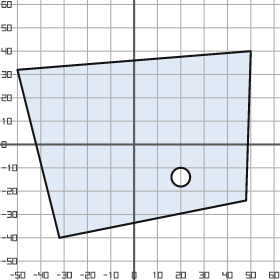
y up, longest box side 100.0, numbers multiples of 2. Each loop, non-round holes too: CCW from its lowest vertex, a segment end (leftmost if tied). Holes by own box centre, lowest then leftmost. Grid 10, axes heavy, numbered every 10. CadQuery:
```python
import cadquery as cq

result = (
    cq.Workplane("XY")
    .moveTo(-32.0, -40.0)
    .lineTo(48.0, -24.0)
    .lineTo(50.0, 40.0)
    .lineTo(-50.0, 32.0)
    .close()
    .moveTo(20.0, -14.0)
    .circle(4.0)
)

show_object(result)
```